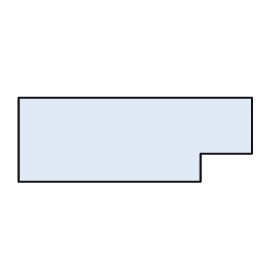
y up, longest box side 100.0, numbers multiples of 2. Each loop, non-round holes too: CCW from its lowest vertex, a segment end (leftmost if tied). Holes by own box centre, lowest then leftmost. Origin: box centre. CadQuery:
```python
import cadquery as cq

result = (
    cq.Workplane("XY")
    .moveTo(-50.0, -18.0)
    .lineTo(28.0, -18.0)
    .lineTo(28.0, -6.0)
    .lineTo(50.0, -6.0)
    .lineTo(50.0, 18.0)
    .lineTo(-50.0, 18.0)
    .close()
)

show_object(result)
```